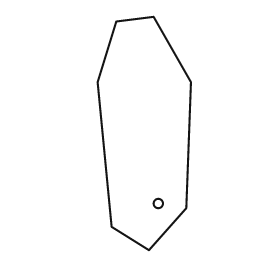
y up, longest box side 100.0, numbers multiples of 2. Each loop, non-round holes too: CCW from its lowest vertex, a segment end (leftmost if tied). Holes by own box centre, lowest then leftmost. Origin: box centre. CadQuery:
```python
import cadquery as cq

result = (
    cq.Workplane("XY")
    .moveTo(2.0, -50.0)
    .lineTo(18.0, -32.0)
    .lineTo(20.0, 22.0)
    .lineTo(4.0, 50.0)
    .lineTo(-12.0, 48.0)
    .lineTo(-20.0, 22.0)
    .lineTo(-14.0, -40.0)
    .close()
    .moveTo(6.0, -30.0)
    .circle(2.0)
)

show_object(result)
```